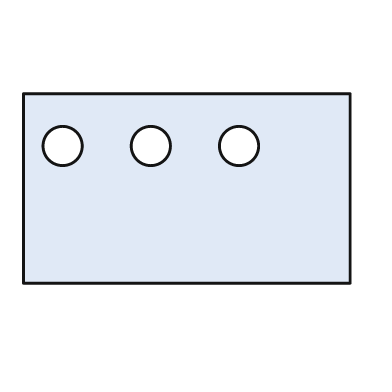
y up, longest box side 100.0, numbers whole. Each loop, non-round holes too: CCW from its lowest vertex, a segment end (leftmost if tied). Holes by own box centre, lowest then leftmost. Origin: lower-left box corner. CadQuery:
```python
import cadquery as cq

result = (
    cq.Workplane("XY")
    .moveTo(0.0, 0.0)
    .lineTo(100.0, 0.0)
    .lineTo(100.0, 58.0)
    .lineTo(0.0, 58.0)
    .close()
    .moveTo(12.0, 42.0)
    .circle(6.0)
    .moveTo(39.0, 42.0)
    .circle(6.0)
    .moveTo(66.0, 42.0)
    .circle(6.0)
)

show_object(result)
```